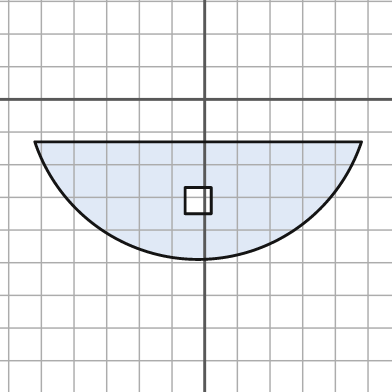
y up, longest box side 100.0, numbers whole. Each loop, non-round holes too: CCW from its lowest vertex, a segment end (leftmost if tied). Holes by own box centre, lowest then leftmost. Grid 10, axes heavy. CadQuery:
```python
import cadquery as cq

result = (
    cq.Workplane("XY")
    .moveTo(-52.0, -13.0)
    .threePointArc((-2.0, -49.0), (48.0, -13.0))
    .close()
    .moveTo(-6.0, -35.0)
    .lineTo(2.0, -35.0)
    .lineTo(2.0, -27.0)
    .lineTo(-6.0, -27.0)
    .close()
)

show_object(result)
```